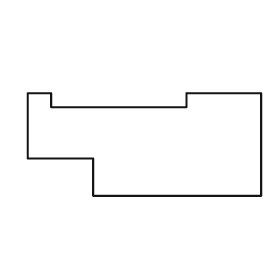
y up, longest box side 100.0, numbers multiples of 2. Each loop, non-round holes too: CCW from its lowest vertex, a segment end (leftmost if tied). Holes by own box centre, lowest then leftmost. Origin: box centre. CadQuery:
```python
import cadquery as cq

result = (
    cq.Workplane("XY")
    .moveTo(-22.0, -22.0)
    .lineTo(50.0, -22.0)
    .lineTo(50.0, 22.0)
    .lineTo(18.0, 22.0)
    .lineTo(18.0, 16.0)
    .lineTo(-40.0, 16.0)
    .lineTo(-40.0, 22.0)
    .lineTo(-50.0, 22.0)
    .lineTo(-50.0, -6.0)
    .lineTo(-22.0, -6.0)
    .close()
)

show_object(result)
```